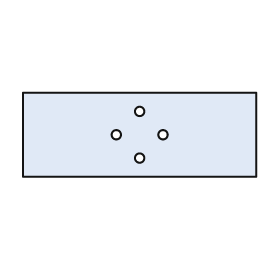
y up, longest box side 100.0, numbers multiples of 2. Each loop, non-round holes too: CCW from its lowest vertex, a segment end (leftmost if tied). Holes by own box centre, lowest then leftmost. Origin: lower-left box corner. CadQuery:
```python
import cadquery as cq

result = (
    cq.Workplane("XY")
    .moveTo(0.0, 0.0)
    .lineTo(100.0, 0.0)
    .lineTo(100.0, 36.0)
    .lineTo(0.0, 36.0)
    .close()
    .moveTo(50.0, 8.0)
    .circle(2.0)
    .moveTo(40.0, 18.0)
    .circle(2.0)
    .moveTo(60.0, 18.0)
    .circle(2.0)
    .moveTo(50.0, 28.0)
    .circle(2.0)
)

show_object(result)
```